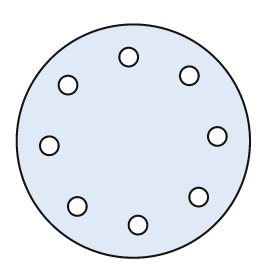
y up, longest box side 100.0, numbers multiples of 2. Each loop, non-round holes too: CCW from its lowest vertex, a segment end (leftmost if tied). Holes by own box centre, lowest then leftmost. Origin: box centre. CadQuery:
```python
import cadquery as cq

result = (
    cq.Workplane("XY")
    .moveTo(0.0, 0.0)
    .circle(50.0)
    .moveTo(2.0, -36.0)
    .circle(4.0)
    .moveTo(-24.0, -28.0)
    .circle(4.0)
    .moveTo(28.0, -24.0)
    .circle(4.0)
    .moveTo(-36.0, -2.0)
    .circle(4.0)
    .moveTo(36.0, 2.0)
    .circle(4.0)
    .moveTo(-28.0, 24.0)
    .circle(4.0)
    .moveTo(24.0, 28.0)
    .circle(4.0)
    .moveTo(-2.0, 36.0)
    .circle(4.0)
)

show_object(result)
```